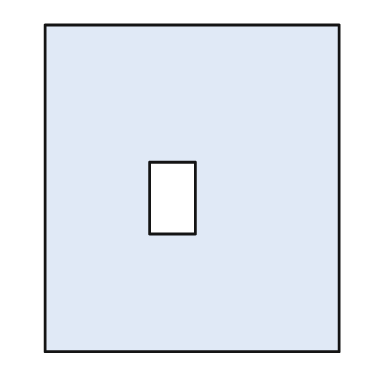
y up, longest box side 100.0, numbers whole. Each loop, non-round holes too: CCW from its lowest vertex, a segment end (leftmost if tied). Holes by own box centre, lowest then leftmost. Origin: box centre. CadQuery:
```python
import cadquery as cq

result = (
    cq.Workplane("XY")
    .moveTo(-45.0, -50.0)
    .lineTo(45.0, -50.0)
    .lineTo(45.0, 50.0)
    .lineTo(-45.0, 50.0)
    .close()
    .moveTo(-13.0, -14.0)
    .lineTo(1.0, -14.0)
    .lineTo(1.0, 8.0)
    .lineTo(-13.0, 8.0)
    .close()
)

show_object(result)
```